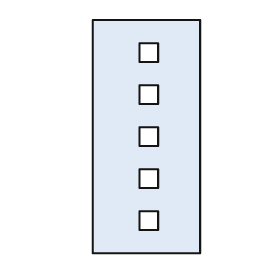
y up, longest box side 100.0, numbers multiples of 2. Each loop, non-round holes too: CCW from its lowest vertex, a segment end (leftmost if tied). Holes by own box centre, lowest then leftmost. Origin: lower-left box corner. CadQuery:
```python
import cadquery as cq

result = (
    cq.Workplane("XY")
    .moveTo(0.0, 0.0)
    .lineTo(46.0, 0.0)
    .lineTo(46.0, 100.0)
    .lineTo(0.0, 100.0)
    .close()
    .moveTo(20.0, 10.0)
    .lineTo(28.0, 10.0)
    .lineTo(28.0, 18.0)
    .lineTo(20.0, 18.0)
    .close()
    .moveTo(20.0, 28.0)
    .lineTo(28.0, 28.0)
    .lineTo(28.0, 36.0)
    .lineTo(20.0, 36.0)
    .close()
    .moveTo(20.0, 46.0)
    .lineTo(28.0, 46.0)
    .lineTo(28.0, 54.0)
    .lineTo(20.0, 54.0)
    .close()
    .moveTo(20.0, 64.0)
    .lineTo(28.0, 64.0)
    .lineTo(28.0, 72.0)
    .lineTo(20.0, 72.0)
    .close()
    .moveTo(20.0, 82.0)
    .lineTo(28.0, 82.0)
    .lineTo(28.0, 90.0)
    .lineTo(20.0, 90.0)
    .close()
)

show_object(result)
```